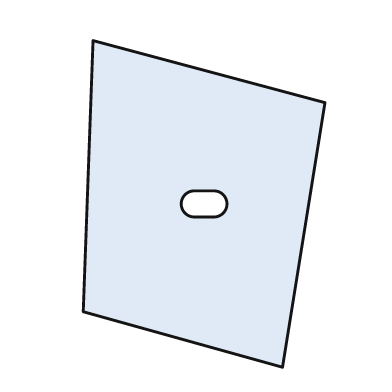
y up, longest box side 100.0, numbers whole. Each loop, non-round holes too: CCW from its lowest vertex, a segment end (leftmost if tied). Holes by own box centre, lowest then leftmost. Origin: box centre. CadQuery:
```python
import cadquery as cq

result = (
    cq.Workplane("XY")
    .moveTo(24.0, -50.0)
    .lineTo(37.0, 31.0)
    .lineTo(-34.0, 50.0)
    .lineTo(-37.0, -33.0)
    .close()
    .moveTo(-3.0, -4.0)
    .lineTo(3.0, -4.0)
    .threePointArc((7.0, 0.0), (3.0, 4.0))
    .lineTo(-3.0, 4.0)
    .threePointArc((-7.0, 0.0), (-3.0, -4.0))
    .close()
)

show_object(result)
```